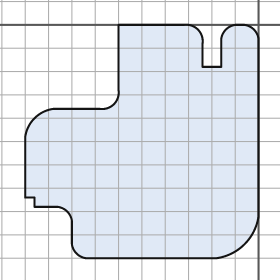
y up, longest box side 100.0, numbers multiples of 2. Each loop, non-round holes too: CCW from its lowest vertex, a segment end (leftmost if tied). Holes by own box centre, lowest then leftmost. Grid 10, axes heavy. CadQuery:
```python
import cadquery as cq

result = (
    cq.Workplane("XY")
    .moveTo(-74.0, -100.0)
    .lineTo(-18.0, -100.0)
    .threePointArc((-6.0, -94.0), (0.0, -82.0))
    .lineTo(0.0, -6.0)
    .threePointArc((-2.0, -2.0), (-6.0, 0.0))
    .lineTo(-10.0, 0.0)
    .threePointArc((-14.0, -2.0), (-16.0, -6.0))
    .lineTo(-16.0, -18.0)
    .lineTo(-24.0, -18.0)
    .lineTo(-24.0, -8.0)
    .threePointArc((-26.0, -2.0), (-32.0, 0.0))
    .lineTo(-60.0, 0.0)
    .lineTo(-60.0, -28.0)
    .threePointArc((-62.0, -34.0), (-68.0, -36.0))
    .lineTo(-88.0, -36.0)
    .threePointArc((-96.0, -40.0), (-100.0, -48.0))
    .lineTo(-100.0, -74.0)
    .lineTo(-96.0, -74.0)
    .lineTo(-96.0, -78.0)
    .lineTo(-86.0, -78.0)
    .threePointArc((-82.0, -80.0), (-80.0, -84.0))
    .lineTo(-80.0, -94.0)
    .threePointArc((-78.0, -98.0), (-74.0, -100.0))
    .close()
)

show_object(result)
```